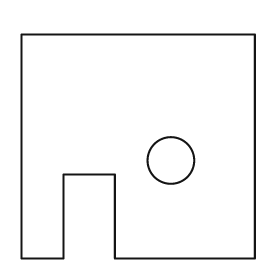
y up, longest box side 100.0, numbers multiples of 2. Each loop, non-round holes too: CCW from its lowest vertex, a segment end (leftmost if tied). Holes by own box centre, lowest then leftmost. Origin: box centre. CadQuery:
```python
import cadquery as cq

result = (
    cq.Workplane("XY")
    .moveTo(-50.0, -48.0)
    .lineTo(-32.0, -48.0)
    .lineTo(-32.0, -12.0)
    .lineTo(-10.0, -12.0)
    .lineTo(-10.0, -48.0)
    .lineTo(50.0, -48.0)
    .lineTo(50.0, 48.0)
    .lineTo(-50.0, 48.0)
    .close()
    .moveTo(14.0, -6.0)
    .circle(10.0)
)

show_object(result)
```